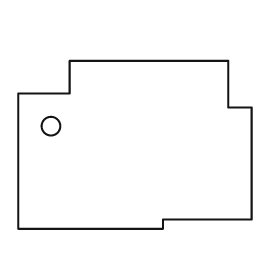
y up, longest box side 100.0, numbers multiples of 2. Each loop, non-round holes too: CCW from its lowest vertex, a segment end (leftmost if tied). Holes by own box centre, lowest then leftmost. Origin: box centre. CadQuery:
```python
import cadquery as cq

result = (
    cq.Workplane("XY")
    .moveTo(-50.0, -36.0)
    .lineTo(12.0, -36.0)
    .lineTo(12.0, -32.0)
    .lineTo(50.0, -32.0)
    .lineTo(50.0, 16.0)
    .lineTo(40.0, 16.0)
    .lineTo(40.0, 36.0)
    .lineTo(-28.0, 36.0)
    .lineTo(-28.0, 22.0)
    .lineTo(-50.0, 22.0)
    .close()
    .moveTo(-36.0, 8.0)
    .circle(4.0)
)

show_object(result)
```